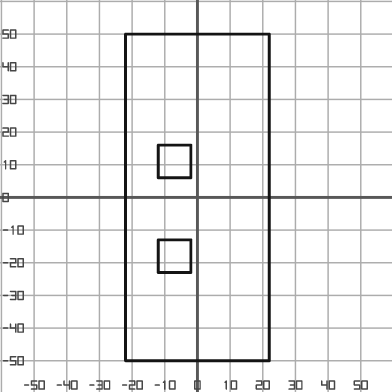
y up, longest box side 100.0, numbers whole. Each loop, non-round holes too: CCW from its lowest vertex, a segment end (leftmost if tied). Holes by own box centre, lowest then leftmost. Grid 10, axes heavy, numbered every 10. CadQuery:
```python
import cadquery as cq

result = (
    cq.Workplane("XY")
    .moveTo(-22.0, -50.0)
    .lineTo(22.0, -50.0)
    .lineTo(22.0, 50.0)
    .lineTo(-22.0, 50.0)
    .close()
    .moveTo(-12.0, -23.0)
    .lineTo(-2.0, -23.0)
    .lineTo(-2.0, -13.0)
    .lineTo(-12.0, -13.0)
    .close()
    .moveTo(-12.0, 6.0)
    .lineTo(-2.0, 6.0)
    .lineTo(-2.0, 16.0)
    .lineTo(-12.0, 16.0)
    .close()
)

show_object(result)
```